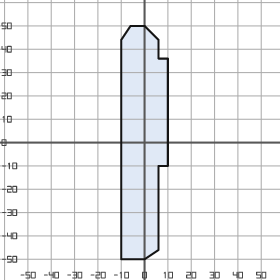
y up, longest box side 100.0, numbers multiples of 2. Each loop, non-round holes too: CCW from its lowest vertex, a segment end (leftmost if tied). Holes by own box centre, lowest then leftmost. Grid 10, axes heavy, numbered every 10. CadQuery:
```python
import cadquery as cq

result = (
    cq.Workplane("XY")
    .moveTo(-10.0, -50.0)
    .lineTo(0.0, -50.0)
    .lineTo(6.0, -46.0)
    .lineTo(6.0, -10.0)
    .lineTo(10.0, -10.0)
    .lineTo(10.0, 36.0)
    .lineTo(6.0, 36.0)
    .lineTo(6.0, 44.0)
    .lineTo(0.0, 50.0)
    .lineTo(-6.0, 50.0)
    .lineTo(-10.0, 44.0)
    .close()
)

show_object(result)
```